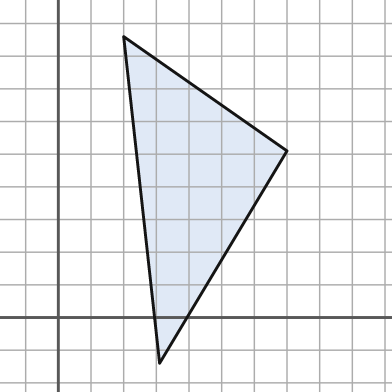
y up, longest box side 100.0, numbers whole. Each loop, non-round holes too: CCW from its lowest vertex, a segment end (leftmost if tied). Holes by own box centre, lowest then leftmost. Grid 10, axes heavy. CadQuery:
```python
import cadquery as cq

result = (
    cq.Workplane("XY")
    .moveTo(31.0, -14.0)
    .lineTo(70.0, 51.0)
    .lineTo(20.0, 86.0)
    .close()
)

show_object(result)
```